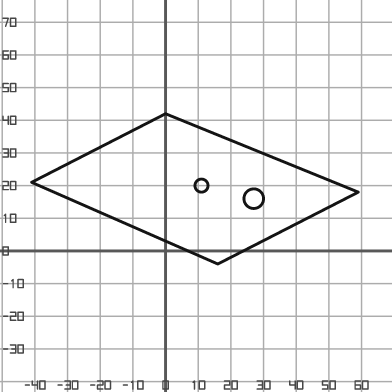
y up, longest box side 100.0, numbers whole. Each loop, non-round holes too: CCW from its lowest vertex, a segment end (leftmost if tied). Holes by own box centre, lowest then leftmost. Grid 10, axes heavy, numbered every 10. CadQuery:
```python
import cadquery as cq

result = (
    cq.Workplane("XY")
    .moveTo(16.0, -4.0)
    .lineTo(59.0, 18.0)
    .lineTo(0.0, 42.0)
    .lineTo(-41.0, 21.0)
    .close()
    .moveTo(27.0, 16.0)
    .circle(3.0)
    .moveTo(11.0, 20.0)
    .circle(2.0)
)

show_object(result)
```